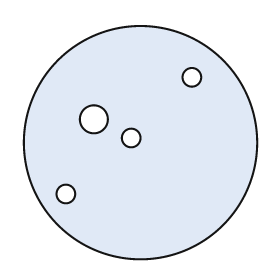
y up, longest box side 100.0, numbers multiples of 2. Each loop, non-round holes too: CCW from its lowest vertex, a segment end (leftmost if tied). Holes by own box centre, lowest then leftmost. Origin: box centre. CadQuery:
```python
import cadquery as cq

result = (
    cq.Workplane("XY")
    .moveTo(0.0, 0.0)
    .circle(50.0)
    .moveTo(-32.0, -22.0)
    .circle(4.0)
    .moveTo(-4.0, 2.0)
    .circle(4.0)
    .moveTo(-20.0, 10.0)
    .circle(6.0)
    .moveTo(22.0, 28.0)
    .circle(4.0)
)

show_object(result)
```